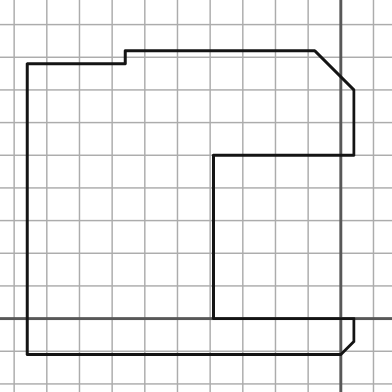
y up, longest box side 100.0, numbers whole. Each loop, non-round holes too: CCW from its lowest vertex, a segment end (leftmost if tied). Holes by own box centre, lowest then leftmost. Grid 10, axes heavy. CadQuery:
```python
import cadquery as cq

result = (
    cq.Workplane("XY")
    .moveTo(-96.0, -11.0)
    .lineTo(0.0, -11.0)
    .lineTo(4.0, -7.0)
    .lineTo(4.0, 0.0)
    .lineTo(-39.0, 0.0)
    .lineTo(-39.0, 50.0)
    .lineTo(4.0, 50.0)
    .lineTo(4.0, 70.0)
    .lineTo(-8.0, 82.0)
    .lineTo(-66.0, 82.0)
    .lineTo(-66.0, 78.0)
    .lineTo(-96.0, 78.0)
    .close()
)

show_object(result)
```